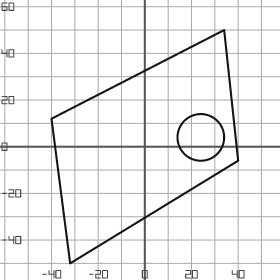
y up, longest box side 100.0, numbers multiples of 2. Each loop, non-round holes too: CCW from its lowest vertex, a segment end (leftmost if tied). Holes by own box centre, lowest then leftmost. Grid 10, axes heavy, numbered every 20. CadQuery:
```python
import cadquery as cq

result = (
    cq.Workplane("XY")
    .moveTo(-32.0, -50.0)
    .lineTo(40.0, -6.0)
    .lineTo(34.0, 50.0)
    .lineTo(-40.0, 12.0)
    .close()
    .moveTo(24.0, 4.0)
    .circle(10.0)
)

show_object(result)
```